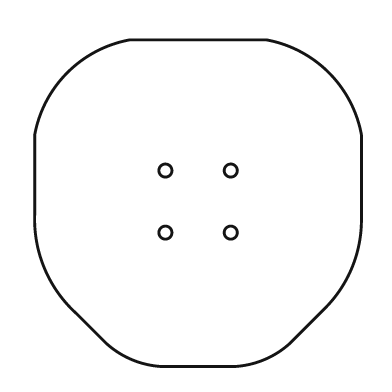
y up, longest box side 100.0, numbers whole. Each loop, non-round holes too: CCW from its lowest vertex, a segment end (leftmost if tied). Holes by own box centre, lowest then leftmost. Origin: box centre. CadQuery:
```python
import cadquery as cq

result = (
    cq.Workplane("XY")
    .moveTo(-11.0, -50.0)
    .lineTo(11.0, -50.0)
    .threePointArc((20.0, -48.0), (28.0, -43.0))
    .lineTo(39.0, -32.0)
    .threePointArc((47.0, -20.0), (50.0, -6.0))
    .lineTo(50.0, 21.0)
    .threePointArc((40.0, 40.0), (21.0, 50.0))
    .lineTo(-21.0, 50.0)
    .threePointArc((-40.0, 40.0), (-50.0, 21.0))
    .lineTo(-50.0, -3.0)
    .threePointArc((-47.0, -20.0), (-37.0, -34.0))
    .lineTo(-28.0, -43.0)
    .threePointArc((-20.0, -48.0), (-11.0, -50.0))
    .close()
    .moveTo(-10.0, -9.0)
    .circle(2.0)
    .moveTo(10.0, -9.0)
    .circle(2.0)
    .moveTo(-10.0, 10.0)
    .circle(2.0)
    .moveTo(10.0, 10.0)
    .circle(2.0)
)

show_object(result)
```